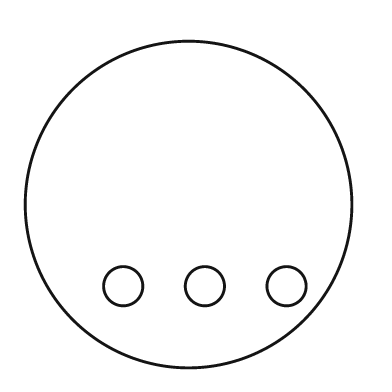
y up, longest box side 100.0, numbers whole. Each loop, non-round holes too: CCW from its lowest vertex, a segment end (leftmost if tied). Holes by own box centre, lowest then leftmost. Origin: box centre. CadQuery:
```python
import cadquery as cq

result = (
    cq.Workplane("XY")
    .moveTo(0.0, 0.0)
    .circle(50.0)
    .moveTo(-20.0, -25.0)
    .circle(6.0)
    .moveTo(5.0, -25.0)
    .circle(6.0)
    .moveTo(30.0, -25.0)
    .circle(6.0)
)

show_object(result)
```